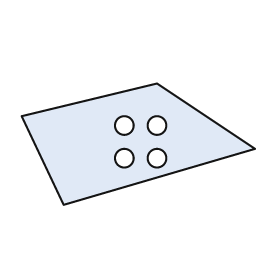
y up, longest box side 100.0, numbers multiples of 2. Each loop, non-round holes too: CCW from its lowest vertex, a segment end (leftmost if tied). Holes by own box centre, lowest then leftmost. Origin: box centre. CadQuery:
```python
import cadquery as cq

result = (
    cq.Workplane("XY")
    .moveTo(-32.0, -26.0)
    .lineTo(50.0, -2.0)
    .lineTo(8.0, 26.0)
    .lineTo(-50.0, 12.0)
    .close()
    .moveTo(-6.0, -6.0)
    .circle(4.0)
    .moveTo(8.0, -6.0)
    .circle(4.0)
    .moveTo(-6.0, 8.0)
    .circle(4.0)
    .moveTo(8.0, 8.0)
    .circle(4.0)
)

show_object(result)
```